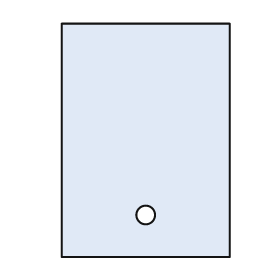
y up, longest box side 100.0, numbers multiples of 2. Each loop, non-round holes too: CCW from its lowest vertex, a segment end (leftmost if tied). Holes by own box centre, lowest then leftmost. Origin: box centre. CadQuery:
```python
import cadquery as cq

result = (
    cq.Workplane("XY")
    .moveTo(-36.0, -50.0)
    .lineTo(36.0, -50.0)
    .lineTo(36.0, 50.0)
    .lineTo(-36.0, 50.0)
    .close()
    .moveTo(0.0, -32.0)
    .circle(4.0)
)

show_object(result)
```